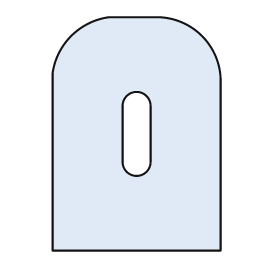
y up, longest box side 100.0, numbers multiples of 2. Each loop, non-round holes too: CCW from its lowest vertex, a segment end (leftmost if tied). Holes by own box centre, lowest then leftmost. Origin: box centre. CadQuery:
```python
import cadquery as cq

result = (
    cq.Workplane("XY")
    .moveTo(-36.0, -50.0)
    .lineTo(36.0, -50.0)
    .lineTo(36.0, 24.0)
    .threePointArc((28.0, 42.0), (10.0, 50.0))
    .lineTo(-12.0, 50.0)
    .threePointArc((-28.0, 42.0), (-36.0, 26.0))
    .close()
    .moveTo(-6.0, -12.0)
    .threePointArc((0.0, -18.0), (6.0, -12.0))
    .lineTo(6.0, 12.0)
    .threePointArc((0.0, 18.0), (-6.0, 12.0))
    .close()
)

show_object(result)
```